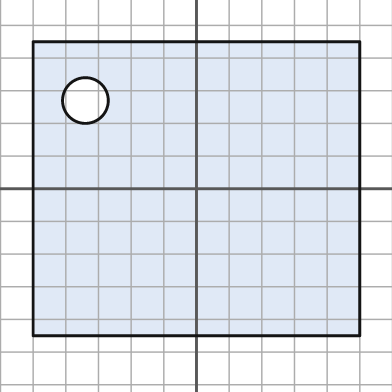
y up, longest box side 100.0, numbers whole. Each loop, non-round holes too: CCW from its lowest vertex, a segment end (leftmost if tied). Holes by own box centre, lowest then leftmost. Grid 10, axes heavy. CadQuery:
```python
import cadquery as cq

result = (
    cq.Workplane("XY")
    .moveTo(-50.0, -45.0)
    .lineTo(50.0, -45.0)
    .lineTo(50.0, 45.0)
    .lineTo(-50.0, 45.0)
    .close()
    .moveTo(-34.0, 27.0)
    .circle(7.0)
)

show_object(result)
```